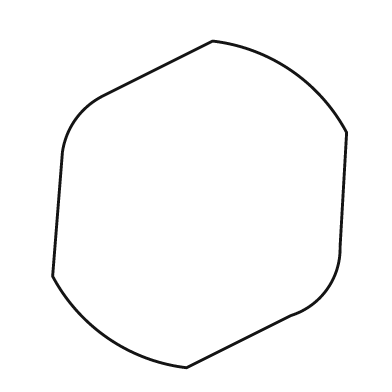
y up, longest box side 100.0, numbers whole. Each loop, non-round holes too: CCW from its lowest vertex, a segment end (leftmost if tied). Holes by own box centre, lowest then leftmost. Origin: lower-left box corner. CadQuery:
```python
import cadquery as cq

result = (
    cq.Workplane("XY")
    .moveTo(41.0, 0.0)
    .lineTo(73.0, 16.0)
    .threePointArc((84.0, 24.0), (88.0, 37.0))
    .lineTo(90.0, 72.0)
    .threePointArc((73.0, 91.0), (49.0, 100.0))
    .lineTo(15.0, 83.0)
    .threePointArc((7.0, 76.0), (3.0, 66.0))
    .lineTo(0.0, 28.0)
    .threePointArc((17.0, 9.0), (41.0, 0.0))
    .close()
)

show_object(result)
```